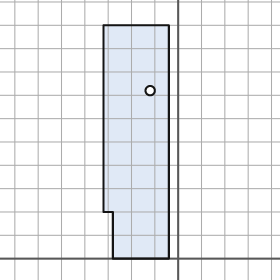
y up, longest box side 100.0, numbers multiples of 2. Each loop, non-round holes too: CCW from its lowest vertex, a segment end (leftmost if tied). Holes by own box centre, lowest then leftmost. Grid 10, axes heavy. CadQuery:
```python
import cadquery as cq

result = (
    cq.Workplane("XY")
    .moveTo(-28.0, 0.0)
    .lineTo(-4.0, 0.0)
    .lineTo(-4.0, 100.0)
    .lineTo(-32.0, 100.0)
    .lineTo(-32.0, 20.0)
    .lineTo(-28.0, 20.0)
    .close()
    .moveTo(-12.0, 72.0)
    .circle(2.0)
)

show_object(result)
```